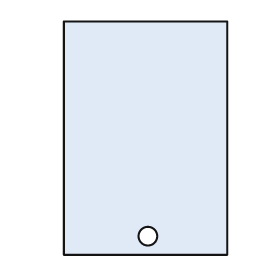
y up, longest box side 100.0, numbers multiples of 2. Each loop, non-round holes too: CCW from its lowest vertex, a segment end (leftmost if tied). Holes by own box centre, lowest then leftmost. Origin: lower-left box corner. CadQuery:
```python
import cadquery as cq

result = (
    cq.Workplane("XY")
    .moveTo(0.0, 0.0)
    .lineTo(70.0, 0.0)
    .lineTo(70.0, 100.0)
    .lineTo(0.0, 100.0)
    .close()
    .moveTo(36.0, 8.0)
    .circle(4.0)
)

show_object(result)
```